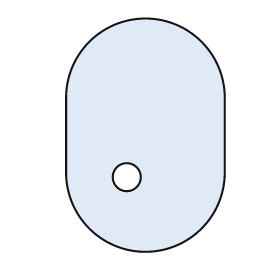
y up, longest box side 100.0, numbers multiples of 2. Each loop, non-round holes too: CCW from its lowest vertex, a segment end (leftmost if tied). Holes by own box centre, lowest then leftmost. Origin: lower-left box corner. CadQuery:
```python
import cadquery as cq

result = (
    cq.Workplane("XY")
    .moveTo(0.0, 34.0)
    .threePointArc((34.0, 0.0), (68.0, 34.0))
    .lineTo(68.0, 66.0)
    .threePointArc((34.0, 100.0), (0.0, 66.0))
    .close()
    .moveTo(26.0, 32.0)
    .circle(6.0)
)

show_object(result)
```